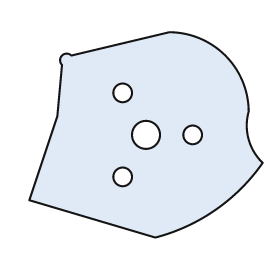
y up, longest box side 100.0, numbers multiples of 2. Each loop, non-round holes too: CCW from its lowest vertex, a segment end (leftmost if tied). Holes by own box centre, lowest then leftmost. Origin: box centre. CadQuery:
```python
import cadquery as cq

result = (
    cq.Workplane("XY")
    .moveTo(4.0, -44.0)
    .threePointArc((30.0, -32.0), (50.0, -12.0))
    .threePointArc((44.0, -2.0), (44.0, 10.0))
    .threePointArc((34.0, 34.0), (10.0, 44.0))
    .lineTo(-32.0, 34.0)
    .threePointArc((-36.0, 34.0), (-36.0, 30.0))
    .lineTo(-38.0, 8.0)
    .lineTo(-50.0, -28.0)
    .close()
    .moveTo(-10.0, -18.0)
    .circle(4.0)
    .moveTo(0.0, 0.0)
    .circle(6.0)
    .moveTo(20.0, 0.0)
    .circle(4.0)
    .moveTo(-10.0, 18.0)
    .circle(4.0)
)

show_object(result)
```